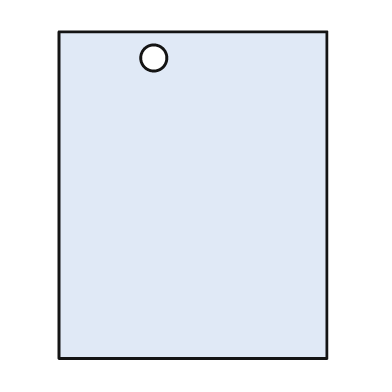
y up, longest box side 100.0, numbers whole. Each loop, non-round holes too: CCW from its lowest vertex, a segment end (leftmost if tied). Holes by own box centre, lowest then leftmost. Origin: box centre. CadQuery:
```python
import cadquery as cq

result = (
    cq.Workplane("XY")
    .moveTo(-41.0, -50.0)
    .lineTo(41.0, -50.0)
    .lineTo(41.0, 50.0)
    .lineTo(-41.0, 50.0)
    .close()
    .moveTo(-12.0, 42.0)
    .circle(4.0)
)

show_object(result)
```